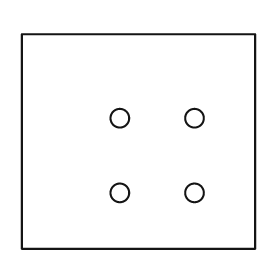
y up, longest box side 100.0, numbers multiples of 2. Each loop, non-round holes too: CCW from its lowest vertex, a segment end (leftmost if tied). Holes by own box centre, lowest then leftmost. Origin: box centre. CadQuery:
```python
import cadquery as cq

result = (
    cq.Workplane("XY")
    .moveTo(-50.0, -46.0)
    .lineTo(50.0, -46.0)
    .lineTo(50.0, 46.0)
    .lineTo(-50.0, 46.0)
    .close()
    .moveTo(-8.0, -22.0)
    .circle(4.0)
    .moveTo(24.0, -22.0)
    .circle(4.0)
    .moveTo(-8.0, 10.0)
    .circle(4.0)
    .moveTo(24.0, 10.0)
    .circle(4.0)
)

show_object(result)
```